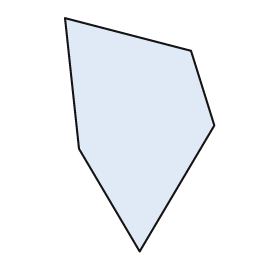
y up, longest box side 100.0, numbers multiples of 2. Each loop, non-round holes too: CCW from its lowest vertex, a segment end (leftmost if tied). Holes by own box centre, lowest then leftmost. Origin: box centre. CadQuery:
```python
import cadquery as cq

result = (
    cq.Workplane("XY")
    .moveTo(0.0, -50.0)
    .lineTo(32.0, 4.0)
    .lineTo(22.0, 36.0)
    .lineTo(-32.0, 50.0)
    .lineTo(-26.0, -6.0)
    .close()
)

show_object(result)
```